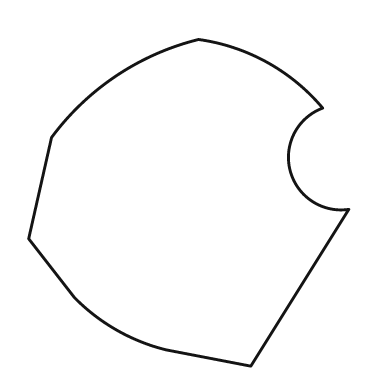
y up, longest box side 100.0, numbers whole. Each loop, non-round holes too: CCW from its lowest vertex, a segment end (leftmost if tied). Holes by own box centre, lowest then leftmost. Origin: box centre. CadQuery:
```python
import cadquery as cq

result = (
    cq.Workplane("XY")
    .moveTo(19.0, -50.0)
    .lineTo(49.0, -2.0)
    .threePointArc((31.0, 10.0), (41.0, 29.0))
    .threePointArc((24.0, 43.0), (3.0, 50.0))
    .threePointArc((-22.0, 39.0), (-42.0, 20.0))
    .lineTo(-49.0, -11.0)
    .lineTo(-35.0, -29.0)
    .threePointArc((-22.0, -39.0), (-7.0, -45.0))
    .close()
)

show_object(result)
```